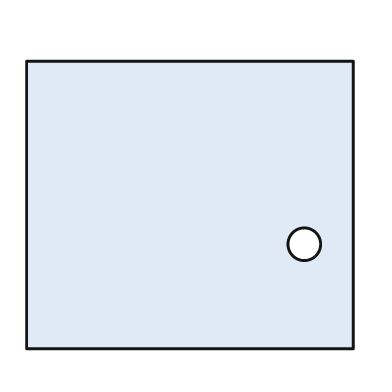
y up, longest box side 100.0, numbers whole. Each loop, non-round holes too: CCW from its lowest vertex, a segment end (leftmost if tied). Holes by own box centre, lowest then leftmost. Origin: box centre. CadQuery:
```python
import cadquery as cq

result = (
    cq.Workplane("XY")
    .moveTo(-50.0, -44.0)
    .lineTo(50.0, -44.0)
    .lineTo(50.0, 44.0)
    .lineTo(-50.0, 44.0)
    .close()
    .moveTo(35.0, -12.0)
    .circle(5.0)
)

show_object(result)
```